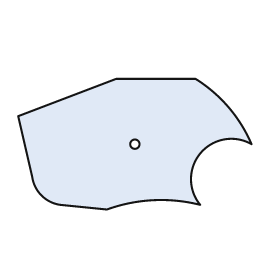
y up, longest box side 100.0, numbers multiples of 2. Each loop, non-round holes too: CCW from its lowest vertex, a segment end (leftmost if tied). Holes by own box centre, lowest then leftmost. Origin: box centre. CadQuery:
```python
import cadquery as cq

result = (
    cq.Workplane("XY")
    .moveTo(-12.0, -28.0)
    .threePointArc((8.0, -24.0), (28.0, -26.0))
    .threePointArc((28.0, -4.0), (50.0, 0.0))
    .threePointArc((40.0, 16.0), (26.0, 28.0))
    .lineTo(-8.0, 28.0)
    .lineTo(-50.0, 12.0)
    .lineTo(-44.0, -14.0)
    .threePointArc((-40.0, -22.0), (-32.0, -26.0))
    .close()
    .moveTo(0.0, 0.0)
    .circle(2.0)
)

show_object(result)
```